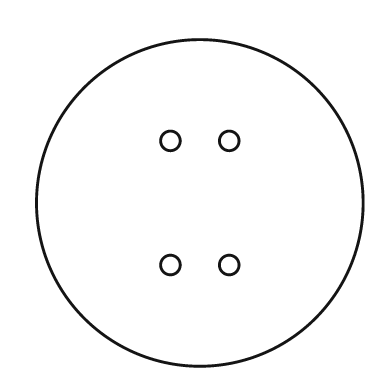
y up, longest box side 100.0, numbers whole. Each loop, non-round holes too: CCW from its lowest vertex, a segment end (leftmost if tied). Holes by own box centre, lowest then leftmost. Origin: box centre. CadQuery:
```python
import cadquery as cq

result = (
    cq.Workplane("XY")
    .moveTo(0.0, 0.0)
    .circle(50.0)
    .moveTo(-9.0, -19.0)
    .circle(3.0)
    .moveTo(9.0, -19.0)
    .circle(3.0)
    .moveTo(-9.0, 19.0)
    .circle(3.0)
    .moveTo(9.0, 19.0)
    .circle(3.0)
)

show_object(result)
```